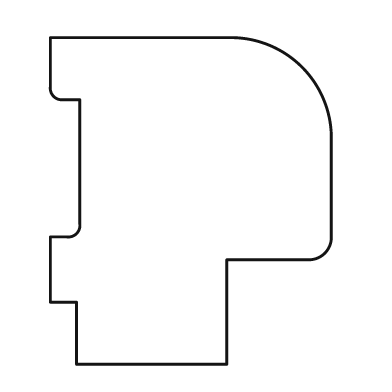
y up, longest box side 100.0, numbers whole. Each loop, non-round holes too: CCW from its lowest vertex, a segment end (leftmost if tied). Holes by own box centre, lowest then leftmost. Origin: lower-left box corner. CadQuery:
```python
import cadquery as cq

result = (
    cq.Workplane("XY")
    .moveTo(8.0, 0.0)
    .lineTo(54.0, 0.0)
    .lineTo(54.0, 32.0)
    .lineTo(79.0, 32.0)
    .threePointArc((84.0, 34.0), (86.0, 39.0))
    .lineTo(86.0, 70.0)
    .threePointArc((77.0, 91.0), (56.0, 100.0))
    .lineTo(0.0, 100.0)
    .lineTo(0.0, 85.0)
    .threePointArc((1.0, 82.0), (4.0, 81.0))
    .lineTo(9.0, 81.0)
    .lineTo(9.0, 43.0)
    .threePointArc((8.0, 40.0), (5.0, 39.0))
    .lineTo(0.0, 39.0)
    .lineTo(0.0, 19.0)
    .lineTo(8.0, 19.0)
    .close()
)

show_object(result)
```